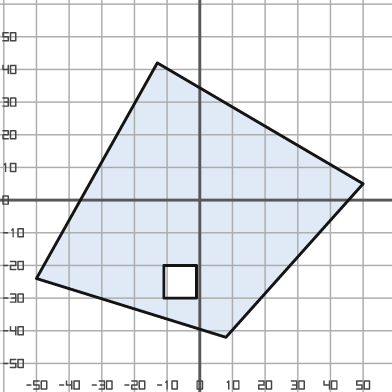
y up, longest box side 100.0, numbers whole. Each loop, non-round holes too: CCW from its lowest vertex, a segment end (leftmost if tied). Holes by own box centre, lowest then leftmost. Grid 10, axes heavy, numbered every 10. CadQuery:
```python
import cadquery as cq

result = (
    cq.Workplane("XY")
    .moveTo(8.0, -42.0)
    .lineTo(50.0, 5.0)
    .lineTo(-13.0, 42.0)
    .lineTo(-50.0, -24.0)
    .close()
    .moveTo(-11.0, -30.0)
    .lineTo(-1.0, -30.0)
    .lineTo(-1.0, -20.0)
    .lineTo(-11.0, -20.0)
    .close()
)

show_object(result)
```